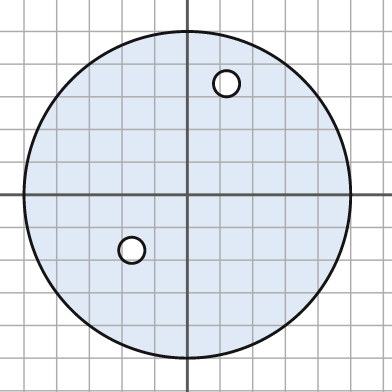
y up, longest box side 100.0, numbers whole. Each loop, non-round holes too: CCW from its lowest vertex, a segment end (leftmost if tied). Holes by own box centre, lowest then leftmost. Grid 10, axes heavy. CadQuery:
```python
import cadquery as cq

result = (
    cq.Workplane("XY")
    .moveTo(0.0, 0.0)
    .circle(50.0)
    .moveTo(-17.0, -17.0)
    .circle(4.0)
    .moveTo(12.0, 34.0)
    .circle(4.0)
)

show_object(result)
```